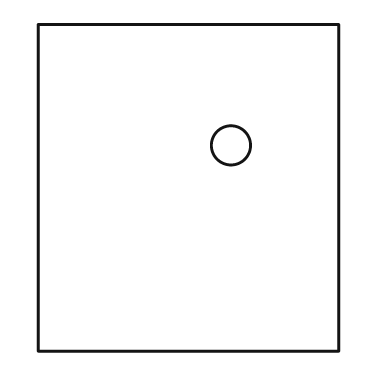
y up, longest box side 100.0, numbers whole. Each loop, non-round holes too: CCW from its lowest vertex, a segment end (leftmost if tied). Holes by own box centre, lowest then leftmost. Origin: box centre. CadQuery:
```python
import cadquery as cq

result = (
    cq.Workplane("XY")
    .moveTo(-46.0, -50.0)
    .lineTo(46.0, -50.0)
    .lineTo(46.0, 50.0)
    .lineTo(-46.0, 50.0)
    .close()
    .moveTo(13.0, 13.0)
    .circle(6.0)
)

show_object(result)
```